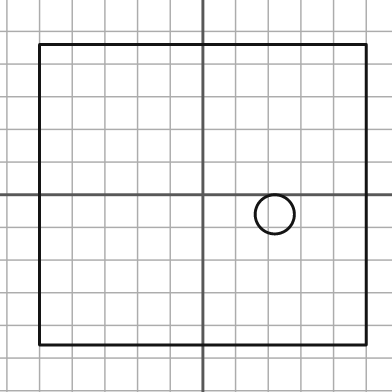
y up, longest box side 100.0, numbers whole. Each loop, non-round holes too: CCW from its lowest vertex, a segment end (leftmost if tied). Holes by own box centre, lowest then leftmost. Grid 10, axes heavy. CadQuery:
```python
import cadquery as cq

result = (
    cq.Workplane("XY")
    .moveTo(-50.0, -46.0)
    .lineTo(50.0, -46.0)
    .lineTo(50.0, 46.0)
    .lineTo(-50.0, 46.0)
    .close()
    .moveTo(22.0, -6.0)
    .circle(6.0)
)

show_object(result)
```